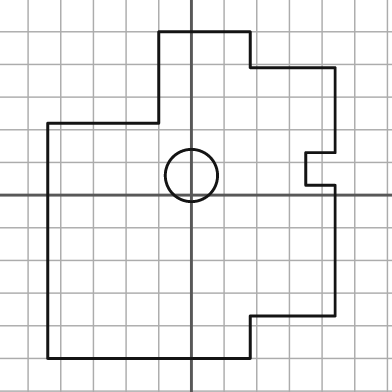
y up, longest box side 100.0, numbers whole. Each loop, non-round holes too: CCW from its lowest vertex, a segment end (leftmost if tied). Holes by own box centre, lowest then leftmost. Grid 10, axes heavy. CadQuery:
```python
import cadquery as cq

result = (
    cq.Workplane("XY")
    .moveTo(-44.0, -50.0)
    .lineTo(18.0, -50.0)
    .lineTo(18.0, -37.0)
    .lineTo(44.0, -37.0)
    .lineTo(44.0, 3.0)
    .lineTo(35.0, 3.0)
    .lineTo(35.0, 13.0)
    .lineTo(44.0, 13.0)
    .lineTo(44.0, 39.0)
    .lineTo(18.0, 39.0)
    .lineTo(18.0, 50.0)
    .lineTo(-10.0, 50.0)
    .lineTo(-10.0, 22.0)
    .lineTo(-44.0, 22.0)
    .close()
    .moveTo(0.0, 6.0)
    .circle(8.0)
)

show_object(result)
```